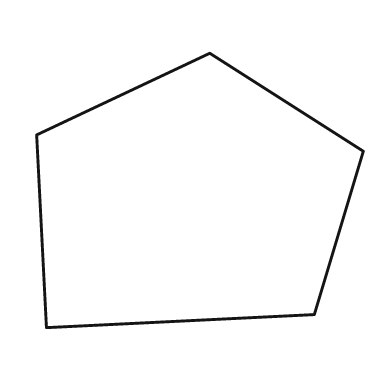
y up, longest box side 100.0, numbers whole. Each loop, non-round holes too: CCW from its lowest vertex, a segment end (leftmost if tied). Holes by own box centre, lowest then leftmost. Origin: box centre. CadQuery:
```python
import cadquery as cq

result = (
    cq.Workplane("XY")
    .moveTo(-47.0, -42.0)
    .lineTo(35.0, -38.0)
    .lineTo(50.0, 12.0)
    .lineTo(3.0, 42.0)
    .lineTo(-50.0, 17.0)
    .close()
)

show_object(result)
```